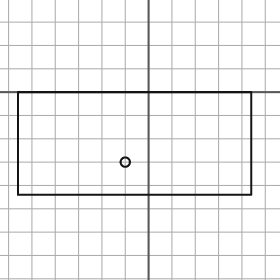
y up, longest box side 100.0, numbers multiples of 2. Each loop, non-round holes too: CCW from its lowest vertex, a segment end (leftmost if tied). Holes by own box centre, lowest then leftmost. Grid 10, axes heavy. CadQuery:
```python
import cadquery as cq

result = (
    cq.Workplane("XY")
    .moveTo(-56.0, -44.0)
    .lineTo(44.0, -44.0)
    .lineTo(44.0, 0.0)
    .lineTo(-56.0, 0.0)
    .close()
    .moveTo(-10.0, -30.0)
    .circle(2.0)
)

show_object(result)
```